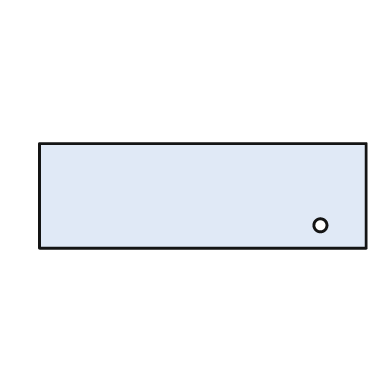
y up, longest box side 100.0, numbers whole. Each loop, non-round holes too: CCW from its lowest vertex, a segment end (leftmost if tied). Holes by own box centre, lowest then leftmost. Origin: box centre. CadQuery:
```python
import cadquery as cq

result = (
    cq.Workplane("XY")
    .moveTo(-50.0, -16.0)
    .lineTo(50.0, -16.0)
    .lineTo(50.0, 16.0)
    .lineTo(-50.0, 16.0)
    .close()
    .moveTo(36.0, -9.0)
    .circle(2.0)
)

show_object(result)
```